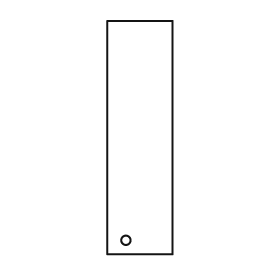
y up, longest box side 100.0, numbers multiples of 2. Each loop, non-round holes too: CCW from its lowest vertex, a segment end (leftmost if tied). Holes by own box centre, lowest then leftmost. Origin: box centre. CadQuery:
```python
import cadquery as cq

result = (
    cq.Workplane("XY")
    .moveTo(-14.0, -50.0)
    .lineTo(14.0, -50.0)
    .lineTo(14.0, 50.0)
    .lineTo(-14.0, 50.0)
    .close()
    .moveTo(-6.0, -44.0)
    .circle(2.0)
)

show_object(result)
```